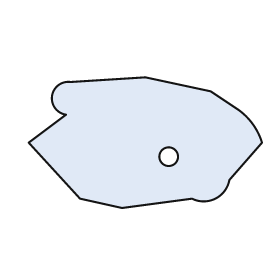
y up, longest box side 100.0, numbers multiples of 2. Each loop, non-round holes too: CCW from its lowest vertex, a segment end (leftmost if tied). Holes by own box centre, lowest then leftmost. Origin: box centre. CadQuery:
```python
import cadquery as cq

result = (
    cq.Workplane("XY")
    .moveTo(-10.0, -28.0)
    .lineTo(20.0, -24.0)
    .threePointArc((30.0, -24.0), (36.0, -16.0))
    .lineTo(50.0, 0.0)
    .threePointArc((46.0, 8.0), (40.0, 14.0))
    .lineTo(28.0, 22.0)
    .lineTo(0.0, 28.0)
    .lineTo(-32.0, 26.0)
    .threePointArc((-40.0, 20.0), (-34.0, 12.0))
    .lineTo(-50.0, 0.0)
    .lineTo(-28.0, -24.0)
    .close()
    .moveTo(10.0, -6.0)
    .circle(4.0)
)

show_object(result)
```